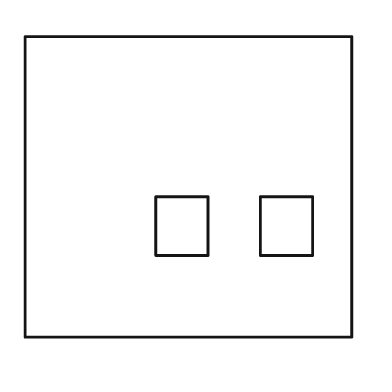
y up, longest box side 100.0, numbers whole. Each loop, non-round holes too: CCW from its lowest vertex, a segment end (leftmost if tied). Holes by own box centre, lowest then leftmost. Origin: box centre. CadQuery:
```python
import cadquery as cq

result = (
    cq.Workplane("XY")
    .moveTo(-50.0, -46.0)
    .lineTo(50.0, -46.0)
    .lineTo(50.0, 46.0)
    .lineTo(-50.0, 46.0)
    .close()
    .moveTo(-10.0, -21.0)
    .lineTo(6.0, -21.0)
    .lineTo(6.0, -3.0)
    .lineTo(-10.0, -3.0)
    .close()
    .moveTo(22.0, -21.0)
    .lineTo(38.0, -21.0)
    .lineTo(38.0, -3.0)
    .lineTo(22.0, -3.0)
    .close()
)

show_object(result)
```